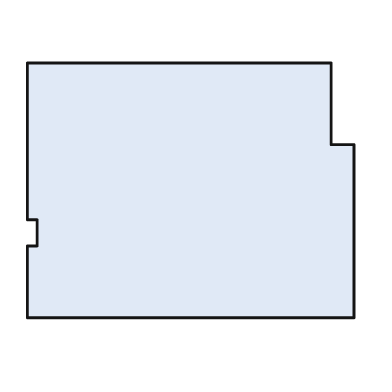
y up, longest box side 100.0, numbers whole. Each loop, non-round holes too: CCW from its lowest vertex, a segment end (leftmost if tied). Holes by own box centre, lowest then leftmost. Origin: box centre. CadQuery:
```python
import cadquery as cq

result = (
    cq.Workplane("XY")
    .moveTo(-50.0, -39.0)
    .lineTo(50.0, -39.0)
    .lineTo(50.0, 14.0)
    .lineTo(43.0, 14.0)
    .lineTo(43.0, 39.0)
    .lineTo(-50.0, 39.0)
    .lineTo(-50.0, -9.0)
    .lineTo(-47.0, -9.0)
    .lineTo(-47.0, -17.0)
    .lineTo(-50.0, -17.0)
    .close()
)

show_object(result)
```